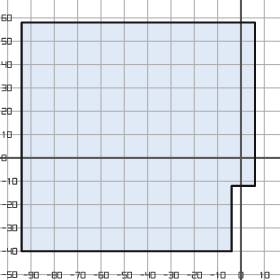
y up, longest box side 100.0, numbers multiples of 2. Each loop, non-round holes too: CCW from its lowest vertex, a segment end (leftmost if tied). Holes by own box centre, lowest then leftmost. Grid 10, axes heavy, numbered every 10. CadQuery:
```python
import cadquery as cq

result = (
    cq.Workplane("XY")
    .moveTo(-94.0, -40.0)
    .lineTo(-4.0, -40.0)
    .lineTo(-4.0, -12.0)
    .lineTo(6.0, -12.0)
    .lineTo(6.0, 58.0)
    .lineTo(-94.0, 58.0)
    .close()
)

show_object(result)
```